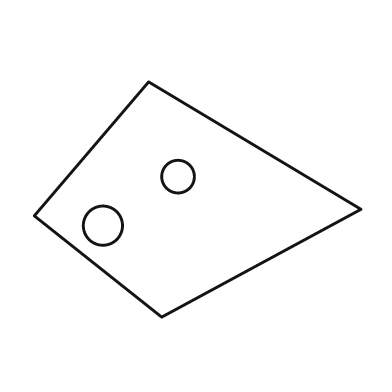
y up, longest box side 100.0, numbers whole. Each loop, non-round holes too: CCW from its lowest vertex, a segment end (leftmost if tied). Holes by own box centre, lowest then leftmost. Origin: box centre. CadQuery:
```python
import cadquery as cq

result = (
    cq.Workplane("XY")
    .moveTo(-11.0, -36.0)
    .lineTo(50.0, -3.0)
    .lineTo(-15.0, 36.0)
    .lineTo(-50.0, -5.0)
    .close()
    .moveTo(-29.0, -8.0)
    .circle(6.0)
    .moveTo(-6.0, 7.0)
    .circle(5.0)
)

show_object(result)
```